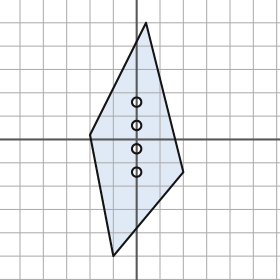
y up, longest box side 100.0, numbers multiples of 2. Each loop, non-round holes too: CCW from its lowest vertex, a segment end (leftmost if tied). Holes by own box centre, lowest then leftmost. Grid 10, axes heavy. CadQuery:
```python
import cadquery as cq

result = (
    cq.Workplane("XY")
    .moveTo(-10.0, -50.0)
    .lineTo(20.0, -14.0)
    .lineTo(4.0, 50.0)
    .lineTo(-20.0, 2.0)
    .close()
    .moveTo(0.0, -14.0)
    .circle(2.0)
    .moveTo(0.0, -4.0)
    .circle(2.0)
    .moveTo(0.0, 6.0)
    .circle(2.0)
    .moveTo(0.0, 16.0)
    .circle(2.0)
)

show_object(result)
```